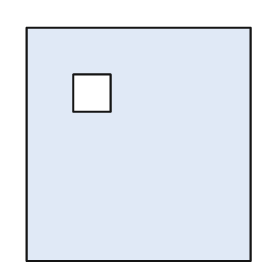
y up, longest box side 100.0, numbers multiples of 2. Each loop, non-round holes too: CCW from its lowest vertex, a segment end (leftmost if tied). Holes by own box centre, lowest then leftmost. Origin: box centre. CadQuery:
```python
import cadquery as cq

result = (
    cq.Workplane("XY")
    .moveTo(-48.0, -50.0)
    .lineTo(48.0, -50.0)
    .lineTo(48.0, 50.0)
    .lineTo(-48.0, 50.0)
    .close()
    .moveTo(-28.0, 14.0)
    .lineTo(-12.0, 14.0)
    .lineTo(-12.0, 30.0)
    .lineTo(-28.0, 30.0)
    .close()
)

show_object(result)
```